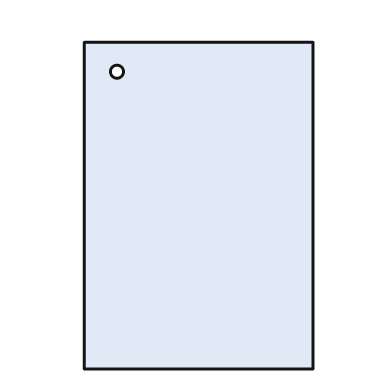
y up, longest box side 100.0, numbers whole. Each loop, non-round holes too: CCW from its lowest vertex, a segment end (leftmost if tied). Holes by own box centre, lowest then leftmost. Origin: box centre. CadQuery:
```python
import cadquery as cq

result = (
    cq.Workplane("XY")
    .moveTo(-35.0, -50.0)
    .lineTo(35.0, -50.0)
    .lineTo(35.0, 50.0)
    .lineTo(-35.0, 50.0)
    .close()
    .moveTo(-25.0, 41.0)
    .circle(2.0)
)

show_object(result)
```